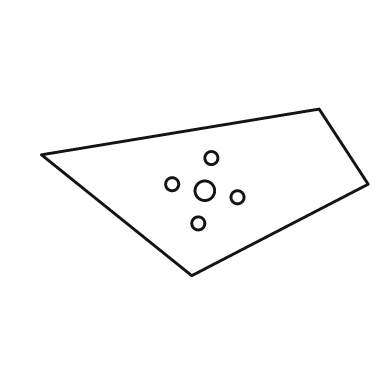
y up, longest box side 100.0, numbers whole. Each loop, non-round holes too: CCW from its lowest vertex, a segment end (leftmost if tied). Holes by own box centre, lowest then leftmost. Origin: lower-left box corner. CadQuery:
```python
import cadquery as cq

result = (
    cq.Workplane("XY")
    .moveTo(46.0, 0.0)
    .lineTo(100.0, 28.0)
    .lineTo(85.0, 51.0)
    .lineTo(0.0, 37.0)
    .close()
    .moveTo(48.0, 16.0)
    .circle(2.0)
    .moveTo(60.0, 24.0)
    .circle(2.0)
    .moveTo(50.0, 26.0)
    .circle(3.0)
    .moveTo(40.0, 28.0)
    .circle(2.0)
    .moveTo(52.0, 36.0)
    .circle(2.0)
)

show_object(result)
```